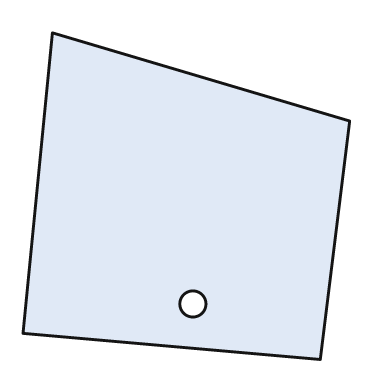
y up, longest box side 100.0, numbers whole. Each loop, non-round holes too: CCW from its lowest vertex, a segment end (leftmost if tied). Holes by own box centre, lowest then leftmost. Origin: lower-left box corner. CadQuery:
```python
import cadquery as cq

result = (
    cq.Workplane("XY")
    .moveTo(91.0, 0.0)
    .lineTo(100.0, 73.0)
    .lineTo(9.0, 100.0)
    .lineTo(0.0, 8.0)
    .close()
    .moveTo(52.0, 17.0)
    .circle(4.0)
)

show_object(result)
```